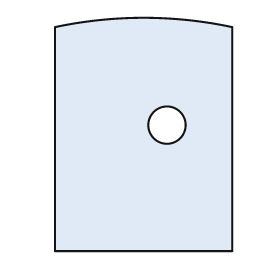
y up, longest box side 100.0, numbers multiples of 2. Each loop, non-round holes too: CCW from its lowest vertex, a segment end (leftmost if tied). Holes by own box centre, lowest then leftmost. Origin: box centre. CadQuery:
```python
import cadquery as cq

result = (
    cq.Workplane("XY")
    .moveTo(-38.0, -50.0)
    .lineTo(38.0, -50.0)
    .lineTo(38.0, 46.0)
    .threePointArc((0.0, 50.0), (-38.0, 46.0))
    .close()
    .moveTo(10.0, 4.0)
    .circle(8.0)
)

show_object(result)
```